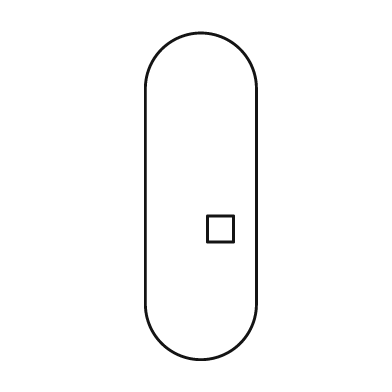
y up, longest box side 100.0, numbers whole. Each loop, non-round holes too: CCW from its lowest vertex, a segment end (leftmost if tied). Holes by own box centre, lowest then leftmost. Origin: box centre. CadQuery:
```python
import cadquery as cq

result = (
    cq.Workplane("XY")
    .moveTo(-17.0, -33.0)
    .threePointArc((0.0, -50.0), (17.0, -33.0))
    .lineTo(17.0, 33.0)
    .threePointArc((0.0, 50.0), (-17.0, 33.0))
    .close()
    .moveTo(2.0, -14.0)
    .lineTo(10.0, -14.0)
    .lineTo(10.0, -6.0)
    .lineTo(2.0, -6.0)
    .close()
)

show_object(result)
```